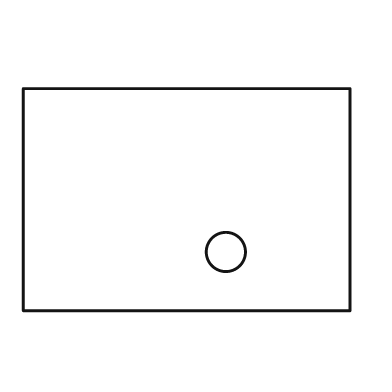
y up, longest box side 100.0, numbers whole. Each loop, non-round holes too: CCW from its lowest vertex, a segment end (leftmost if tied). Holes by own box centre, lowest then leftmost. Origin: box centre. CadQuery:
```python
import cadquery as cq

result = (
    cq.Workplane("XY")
    .moveTo(-50.0, -34.0)
    .lineTo(50.0, -34.0)
    .lineTo(50.0, 34.0)
    .lineTo(-50.0, 34.0)
    .close()
    .moveTo(12.0, -16.0)
    .circle(6.0)
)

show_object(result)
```